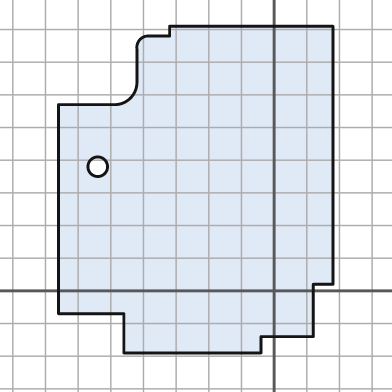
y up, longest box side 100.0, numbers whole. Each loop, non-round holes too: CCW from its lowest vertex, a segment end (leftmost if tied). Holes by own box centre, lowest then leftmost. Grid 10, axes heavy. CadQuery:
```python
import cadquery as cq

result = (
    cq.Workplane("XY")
    .moveTo(-46.0, -19.0)
    .lineTo(-4.0, -19.0)
    .lineTo(-4.0, -14.0)
    .lineTo(12.0, -14.0)
    .lineTo(12.0, 2.0)
    .lineTo(18.0, 2.0)
    .lineTo(18.0, 81.0)
    .lineTo(-32.0, 81.0)
    .lineTo(-32.0, 78.0)
    .lineTo(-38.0, 78.0)
    .threePointArc((-41.0, 77.0), (-42.0, 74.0))
    .lineTo(-42.0, 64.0)
    .threePointArc((-44.0, 59.0), (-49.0, 57.0))
    .lineTo(-66.0, 57.0)
    .lineTo(-66.0, -7.0)
    .lineTo(-46.0, -7.0)
    .close()
    .moveTo(-54.0, 38.0)
    .circle(3.0)
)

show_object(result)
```